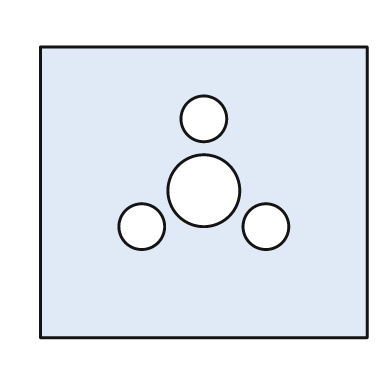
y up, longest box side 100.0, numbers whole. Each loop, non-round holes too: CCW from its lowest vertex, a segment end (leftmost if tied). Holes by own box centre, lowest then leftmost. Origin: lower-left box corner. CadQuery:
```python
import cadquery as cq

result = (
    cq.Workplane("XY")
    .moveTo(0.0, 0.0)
    .lineTo(100.0, 0.0)
    .lineTo(100.0, 89.0)
    .lineTo(0.0, 89.0)
    .close()
    .moveTo(31.0, 34.0)
    .circle(7.0)
    .moveTo(69.0, 34.0)
    .circle(7.0)
    .moveTo(50.0, 45.0)
    .circle(11.0)
    .moveTo(50.0, 67.0)
    .circle(7.0)
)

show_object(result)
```